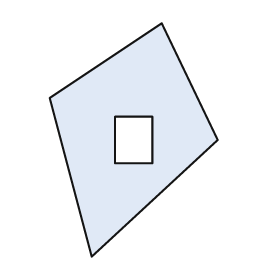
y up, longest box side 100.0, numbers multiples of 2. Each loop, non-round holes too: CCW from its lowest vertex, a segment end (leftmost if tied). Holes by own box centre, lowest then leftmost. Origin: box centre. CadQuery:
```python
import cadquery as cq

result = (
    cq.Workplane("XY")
    .moveTo(-18.0, -50.0)
    .lineTo(36.0, 0.0)
    .lineTo(12.0, 50.0)
    .lineTo(-36.0, 18.0)
    .close()
    .moveTo(-8.0, -10.0)
    .lineTo(8.0, -10.0)
    .lineTo(8.0, 10.0)
    .lineTo(-8.0, 10.0)
    .close()
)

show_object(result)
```